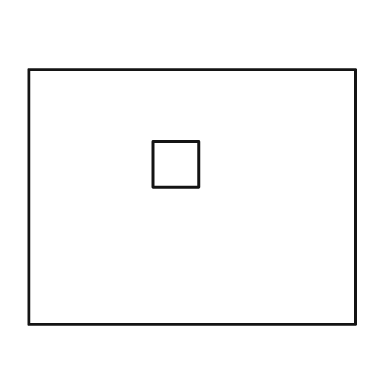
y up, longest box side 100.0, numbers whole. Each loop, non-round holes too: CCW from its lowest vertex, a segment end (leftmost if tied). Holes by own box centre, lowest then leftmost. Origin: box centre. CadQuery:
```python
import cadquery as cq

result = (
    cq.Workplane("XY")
    .moveTo(-50.0, -39.0)
    .lineTo(50.0, -39.0)
    .lineTo(50.0, 39.0)
    .lineTo(-50.0, 39.0)
    .close()
    .moveTo(-12.0, 3.0)
    .lineTo(2.0, 3.0)
    .lineTo(2.0, 17.0)
    .lineTo(-12.0, 17.0)
    .close()
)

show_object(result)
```